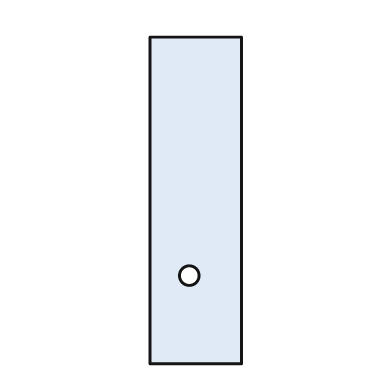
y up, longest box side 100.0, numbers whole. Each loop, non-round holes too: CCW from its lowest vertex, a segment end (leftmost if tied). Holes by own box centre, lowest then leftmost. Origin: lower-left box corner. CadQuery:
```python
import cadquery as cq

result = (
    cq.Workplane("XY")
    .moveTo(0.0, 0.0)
    .lineTo(28.0, 0.0)
    .lineTo(28.0, 100.0)
    .lineTo(0.0, 100.0)
    .close()
    .moveTo(12.0, 27.0)
    .circle(3.0)
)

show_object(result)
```